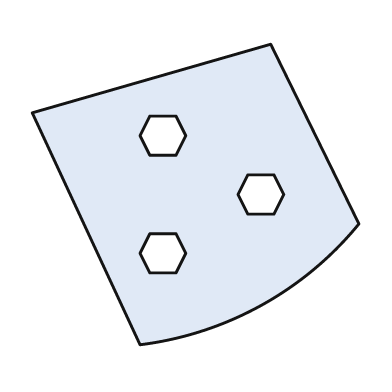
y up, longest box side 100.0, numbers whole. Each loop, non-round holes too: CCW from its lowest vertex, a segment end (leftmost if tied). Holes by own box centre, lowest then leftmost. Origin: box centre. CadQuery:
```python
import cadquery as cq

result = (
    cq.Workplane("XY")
    .moveTo(-17.0, -46.0)
    .threePointArc((20.0, -34.0), (50.0, -9.0))
    .lineTo(23.0, 46.0)
    .lineTo(-50.0, 25.0)
    .close()
    .moveTo(-14.0, -24.0)
    .lineTo(-6.0, -24.0)
    .lineTo(-3.0, -18.0)
    .lineTo(-6.0, -12.0)
    .lineTo(-14.0, -12.0)
    .lineTo(-17.0, -18.0)
    .close()
    .moveTo(16.0, -6.0)
    .lineTo(24.0, -6.0)
    .lineTo(27.0, 0.0)
    .lineTo(24.0, 6.0)
    .lineTo(16.0, 6.0)
    .lineTo(13.0, 0.0)
    .close()
    .moveTo(-14.0, 12.0)
    .lineTo(-6.0, 12.0)
    .lineTo(-3.0, 18.0)
    .lineTo(-6.0, 24.0)
    .lineTo(-14.0, 24.0)
    .lineTo(-17.0, 18.0)
    .close()
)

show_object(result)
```